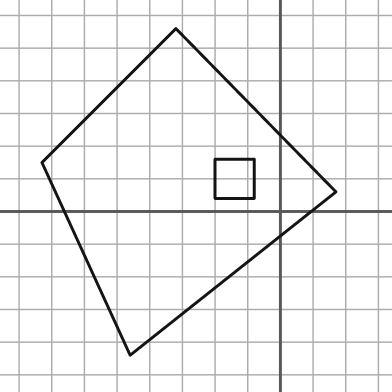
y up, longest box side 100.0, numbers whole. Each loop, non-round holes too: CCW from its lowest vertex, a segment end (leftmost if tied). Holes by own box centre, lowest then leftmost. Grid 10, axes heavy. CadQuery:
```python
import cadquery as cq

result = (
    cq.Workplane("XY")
    .moveTo(-46.0, -44.0)
    .lineTo(17.0, 6.0)
    .lineTo(-32.0, 56.0)
    .lineTo(-73.0, 15.0)
    .close()
    .moveTo(-20.0, 4.0)
    .lineTo(-8.0, 4.0)
    .lineTo(-8.0, 16.0)
    .lineTo(-20.0, 16.0)
    .close()
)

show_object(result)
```